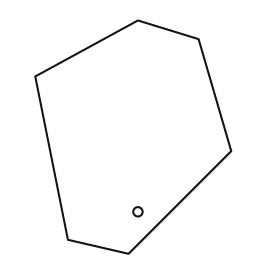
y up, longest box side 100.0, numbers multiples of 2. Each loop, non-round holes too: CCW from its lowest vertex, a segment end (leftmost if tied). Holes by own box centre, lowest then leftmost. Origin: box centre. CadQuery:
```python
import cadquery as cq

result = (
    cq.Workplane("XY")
    .moveTo(-2.0, -50.0)
    .lineTo(42.0, -6.0)
    .lineTo(28.0, 42.0)
    .lineTo(2.0, 50.0)
    .lineTo(-42.0, 26.0)
    .lineTo(-28.0, -44.0)
    .close()
    .moveTo(2.0, -32.0)
    .circle(2.0)
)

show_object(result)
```